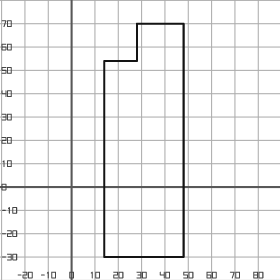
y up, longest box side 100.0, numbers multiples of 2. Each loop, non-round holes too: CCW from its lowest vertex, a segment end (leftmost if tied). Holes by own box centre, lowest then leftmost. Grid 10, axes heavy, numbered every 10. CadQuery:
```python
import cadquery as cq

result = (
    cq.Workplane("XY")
    .moveTo(14.0, -30.0)
    .lineTo(48.0, -30.0)
    .lineTo(48.0, 70.0)
    .lineTo(28.0, 70.0)
    .lineTo(28.0, 54.0)
    .lineTo(14.0, 54.0)
    .close()
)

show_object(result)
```